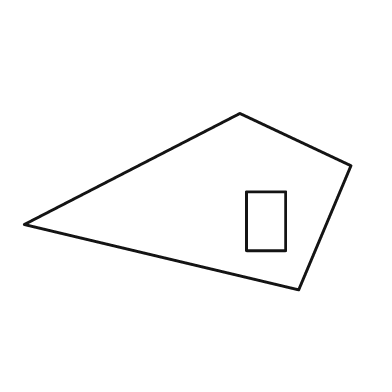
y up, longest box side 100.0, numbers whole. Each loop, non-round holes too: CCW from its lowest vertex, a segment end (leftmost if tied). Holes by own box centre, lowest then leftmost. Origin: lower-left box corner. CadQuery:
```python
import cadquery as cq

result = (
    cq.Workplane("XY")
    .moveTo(84.0, 0.0)
    .lineTo(100.0, 38.0)
    .lineTo(66.0, 54.0)
    .lineTo(0.0, 20.0)
    .close()
    .moveTo(68.0, 12.0)
    .lineTo(80.0, 12.0)
    .lineTo(80.0, 30.0)
    .lineTo(68.0, 30.0)
    .close()
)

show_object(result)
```